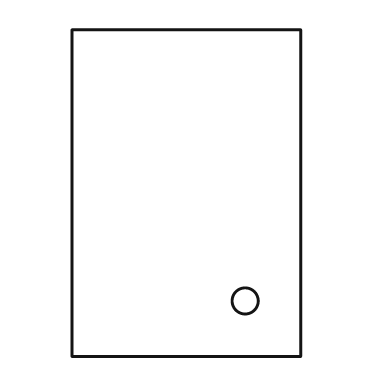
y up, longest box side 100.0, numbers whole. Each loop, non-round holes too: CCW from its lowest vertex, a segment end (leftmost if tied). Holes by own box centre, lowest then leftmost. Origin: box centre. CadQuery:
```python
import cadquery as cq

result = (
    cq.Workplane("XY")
    .moveTo(-35.0, -50.0)
    .lineTo(35.0, -50.0)
    .lineTo(35.0, 50.0)
    .lineTo(-35.0, 50.0)
    .close()
    .moveTo(18.0, -33.0)
    .circle(4.0)
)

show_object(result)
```